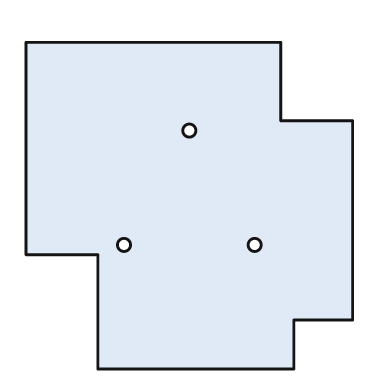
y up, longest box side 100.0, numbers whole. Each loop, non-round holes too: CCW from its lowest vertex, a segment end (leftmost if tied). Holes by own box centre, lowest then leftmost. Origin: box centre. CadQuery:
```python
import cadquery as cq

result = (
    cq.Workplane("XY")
    .moveTo(-28.0, -50.0)
    .lineTo(32.0, -50.0)
    .lineTo(32.0, -35.0)
    .lineTo(50.0, -35.0)
    .lineTo(50.0, 26.0)
    .lineTo(28.0, 26.0)
    .lineTo(28.0, 50.0)
    .lineTo(-50.0, 50.0)
    .lineTo(-50.0, -15.0)
    .lineTo(-28.0, -15.0)
    .close()
    .moveTo(-20.0, -12.0)
    .circle(2.0)
    .moveTo(20.0, -12.0)
    .circle(2.0)
    .moveTo(0.0, 23.0)
    .circle(2.0)
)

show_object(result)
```